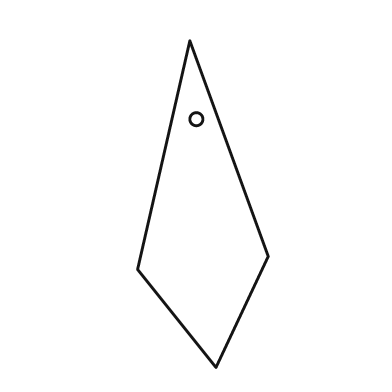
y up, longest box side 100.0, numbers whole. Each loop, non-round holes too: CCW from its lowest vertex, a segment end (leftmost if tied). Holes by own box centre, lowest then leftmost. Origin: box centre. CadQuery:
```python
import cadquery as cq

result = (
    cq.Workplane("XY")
    .moveTo(4.0, -50.0)
    .lineTo(20.0, -16.0)
    .lineTo(-4.0, 50.0)
    .lineTo(-20.0, -20.0)
    .close()
    .moveTo(-2.0, 26.0)
    .circle(2.0)
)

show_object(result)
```